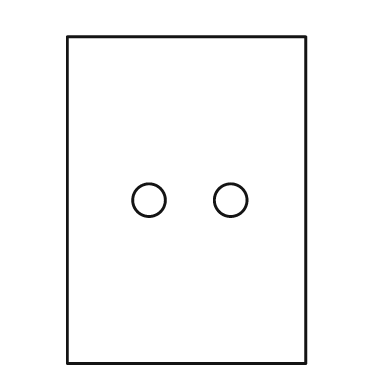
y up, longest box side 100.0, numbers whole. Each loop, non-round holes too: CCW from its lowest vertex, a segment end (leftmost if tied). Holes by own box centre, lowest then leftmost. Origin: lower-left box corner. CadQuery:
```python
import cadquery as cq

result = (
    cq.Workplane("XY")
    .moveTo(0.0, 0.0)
    .lineTo(73.0, 0.0)
    .lineTo(73.0, 100.0)
    .lineTo(0.0, 100.0)
    .close()
    .moveTo(25.0, 50.0)
    .circle(5.0)
    .moveTo(50.0, 50.0)
    .circle(5.0)
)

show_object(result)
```